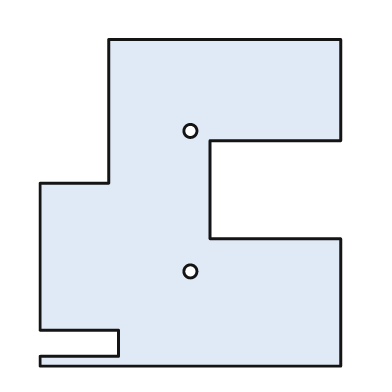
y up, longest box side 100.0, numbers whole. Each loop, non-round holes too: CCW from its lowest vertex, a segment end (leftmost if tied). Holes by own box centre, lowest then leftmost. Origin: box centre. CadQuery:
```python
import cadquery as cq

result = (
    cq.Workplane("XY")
    .moveTo(-46.0, -50.0)
    .lineTo(46.0, -50.0)
    .lineTo(46.0, -11.0)
    .lineTo(6.0, -11.0)
    .lineTo(6.0, 19.0)
    .lineTo(46.0, 19.0)
    .lineTo(46.0, 50.0)
    .lineTo(-25.0, 50.0)
    .lineTo(-25.0, 6.0)
    .lineTo(-46.0, 6.0)
    .lineTo(-46.0, -39.0)
    .lineTo(-22.0, -39.0)
    .lineTo(-22.0, -47.0)
    .lineTo(-46.0, -47.0)
    .close()
    .moveTo(0.0, -21.0)
    .circle(2.0)
    .moveTo(0.0, 22.0)
    .circle(2.0)
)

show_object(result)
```